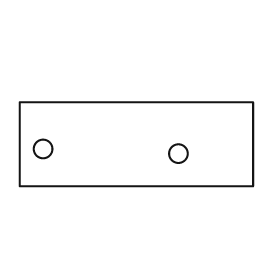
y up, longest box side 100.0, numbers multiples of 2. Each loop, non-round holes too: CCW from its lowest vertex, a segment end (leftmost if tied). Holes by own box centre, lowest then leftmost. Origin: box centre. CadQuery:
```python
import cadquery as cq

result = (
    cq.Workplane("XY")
    .moveTo(-50.0, -18.0)
    .lineTo(50.0, -18.0)
    .lineTo(50.0, 18.0)
    .lineTo(-50.0, 18.0)
    .close()
    .moveTo(18.0, -4.0)
    .circle(4.0)
    .moveTo(-40.0, -2.0)
    .circle(4.0)
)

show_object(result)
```